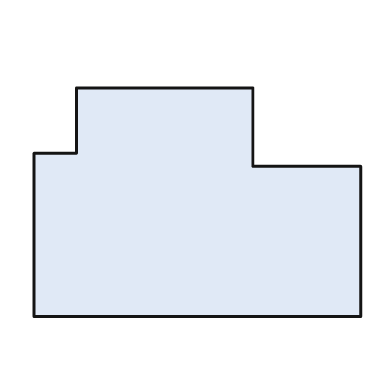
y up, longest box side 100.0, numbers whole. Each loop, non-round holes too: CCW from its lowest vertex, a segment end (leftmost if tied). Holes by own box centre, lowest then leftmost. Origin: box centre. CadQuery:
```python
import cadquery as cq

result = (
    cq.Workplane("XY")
    .moveTo(-50.0, -35.0)
    .lineTo(50.0, -35.0)
    .lineTo(50.0, 11.0)
    .lineTo(17.0, 11.0)
    .lineTo(17.0, 35.0)
    .lineTo(-37.0, 35.0)
    .lineTo(-37.0, 15.0)
    .lineTo(-50.0, 15.0)
    .close()
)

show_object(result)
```